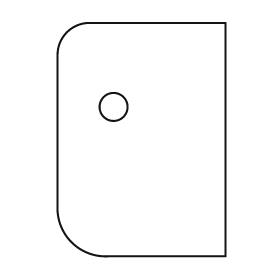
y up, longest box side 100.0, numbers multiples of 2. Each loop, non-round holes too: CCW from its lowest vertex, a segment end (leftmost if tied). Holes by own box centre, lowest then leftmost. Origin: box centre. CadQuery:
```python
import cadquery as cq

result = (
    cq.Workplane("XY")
    .moveTo(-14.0, -50.0)
    .lineTo(36.0, -50.0)
    .lineTo(36.0, 50.0)
    .lineTo(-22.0, 50.0)
    .threePointArc((-32.0, 46.0), (-36.0, 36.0))
    .lineTo(-36.0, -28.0)
    .threePointArc((-30.0, -44.0), (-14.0, -50.0))
    .close()
    .moveTo(-12.0, 14.0)
    .circle(6.0)
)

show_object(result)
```